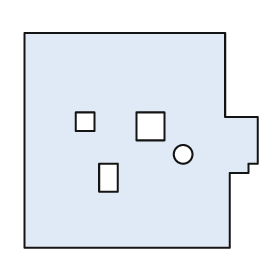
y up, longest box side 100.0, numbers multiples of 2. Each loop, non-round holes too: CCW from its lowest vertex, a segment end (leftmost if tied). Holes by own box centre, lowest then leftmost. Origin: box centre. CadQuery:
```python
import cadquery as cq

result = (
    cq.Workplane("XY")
    .moveTo(-50.0, -46.0)
    .lineTo(38.0, -46.0)
    .lineTo(38.0, -14.0)
    .lineTo(46.0, -14.0)
    .lineTo(46.0, -10.0)
    .lineTo(50.0, -10.0)
    .lineTo(50.0, 10.0)
    .lineTo(36.0, 10.0)
    .lineTo(36.0, 46.0)
    .lineTo(-50.0, 46.0)
    .close()
    .moveTo(-18.0, -22.0)
    .lineTo(-10.0, -22.0)
    .lineTo(-10.0, -10.0)
    .lineTo(-18.0, -10.0)
    .close()
    .moveTo(18.0, -6.0)
    .circle(4.0)
    .moveTo(-2.0, 0.0)
    .lineTo(10.0, 0.0)
    .lineTo(10.0, 12.0)
    .lineTo(-2.0, 12.0)
    .close()
    .moveTo(-28.0, 4.0)
    .lineTo(-20.0, 4.0)
    .lineTo(-20.0, 12.0)
    .lineTo(-28.0, 12.0)
    .close()
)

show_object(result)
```